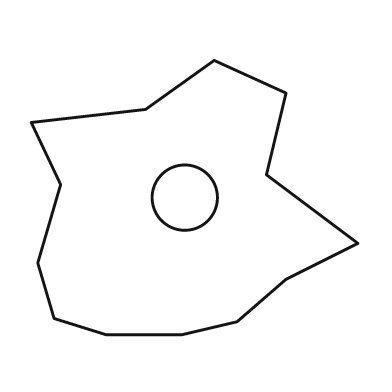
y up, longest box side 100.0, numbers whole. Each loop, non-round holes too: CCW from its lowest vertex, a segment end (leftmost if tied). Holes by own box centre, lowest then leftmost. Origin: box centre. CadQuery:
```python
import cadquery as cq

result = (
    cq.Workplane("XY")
    .moveTo(-27.0, -42.0)
    .lineTo(-4.0, -42.0)
    .lineTo(13.0, -38.0)
    .lineTo(28.0, -25.0)
    .lineTo(50.0, -14.0)
    .lineTo(22.0, 7.0)
    .lineTo(28.0, 32.0)
    .lineTo(6.0, 42.0)
    .lineTo(-15.0, 27.0)
    .lineTo(-50.0, 23.0)
    .lineTo(-41.0, 4.0)
    .lineTo(-48.0, -20.0)
    .lineTo(-43.0, -37.0)
    .close()
    .moveTo(-3.0, 0.0)
    .circle(10.0)
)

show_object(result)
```